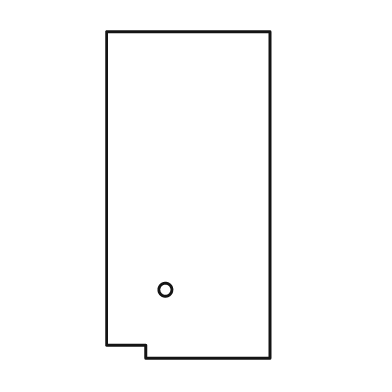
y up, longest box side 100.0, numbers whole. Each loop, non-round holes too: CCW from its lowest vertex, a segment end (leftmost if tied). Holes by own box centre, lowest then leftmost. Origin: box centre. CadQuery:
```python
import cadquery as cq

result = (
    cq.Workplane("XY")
    .moveTo(-13.0, -50.0)
    .lineTo(25.0, -50.0)
    .lineTo(25.0, 50.0)
    .lineTo(-25.0, 50.0)
    .lineTo(-25.0, -46.0)
    .lineTo(-13.0, -46.0)
    .close()
    .moveTo(-7.0, -29.0)
    .circle(2.0)
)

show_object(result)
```